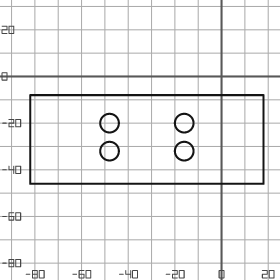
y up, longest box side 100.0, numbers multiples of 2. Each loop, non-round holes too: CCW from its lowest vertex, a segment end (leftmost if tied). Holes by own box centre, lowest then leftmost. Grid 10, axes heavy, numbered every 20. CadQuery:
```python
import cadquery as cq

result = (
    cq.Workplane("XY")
    .moveTo(-82.0, -46.0)
    .lineTo(18.0, -46.0)
    .lineTo(18.0, -8.0)
    .lineTo(-82.0, -8.0)
    .close()
    .moveTo(-48.0, -32.0)
    .circle(4.0)
    .moveTo(-16.0, -32.0)
    .circle(4.0)
    .moveTo(-48.0, -20.0)
    .circle(4.0)
    .moveTo(-16.0, -20.0)
    .circle(4.0)
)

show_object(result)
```